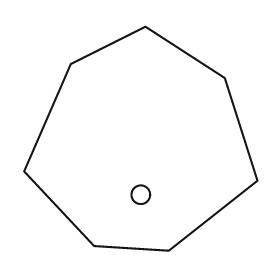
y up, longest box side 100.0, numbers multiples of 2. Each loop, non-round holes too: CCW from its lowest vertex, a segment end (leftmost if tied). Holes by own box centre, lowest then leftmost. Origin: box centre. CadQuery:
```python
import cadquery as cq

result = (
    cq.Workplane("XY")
    .moveTo(12.0, -48.0)
    .lineTo(50.0, -18.0)
    .lineTo(36.0, 26.0)
    .lineTo(2.0, 48.0)
    .lineTo(-30.0, 32.0)
    .lineTo(-50.0, -14.0)
    .lineTo(-20.0, -46.0)
    .close()
    .moveTo(0.0, -24.0)
    .circle(4.0)
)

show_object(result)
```